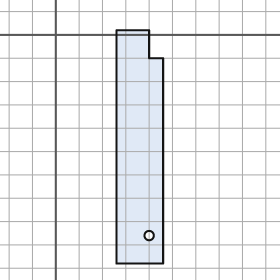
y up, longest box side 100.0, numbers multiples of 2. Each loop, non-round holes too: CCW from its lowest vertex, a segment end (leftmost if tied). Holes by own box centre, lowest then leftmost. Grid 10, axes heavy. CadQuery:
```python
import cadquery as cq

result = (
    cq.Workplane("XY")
    .moveTo(26.0, -98.0)
    .lineTo(46.0, -98.0)
    .lineTo(46.0, -10.0)
    .lineTo(40.0, -10.0)
    .lineTo(40.0, 2.0)
    .lineTo(26.0, 2.0)
    .close()
    .moveTo(40.0, -86.0)
    .circle(2.0)
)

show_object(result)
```